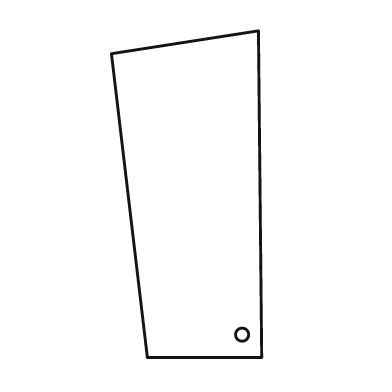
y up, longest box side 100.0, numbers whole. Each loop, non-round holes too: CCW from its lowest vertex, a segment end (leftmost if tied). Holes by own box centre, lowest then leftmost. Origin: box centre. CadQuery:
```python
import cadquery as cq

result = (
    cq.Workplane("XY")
    .moveTo(-12.0, -50.0)
    .lineTo(23.0, -50.0)
    .lineTo(22.0, 50.0)
    .lineTo(-23.0, 43.0)
    .close()
    .moveTo(17.0, -43.0)
    .circle(2.0)
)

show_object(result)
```